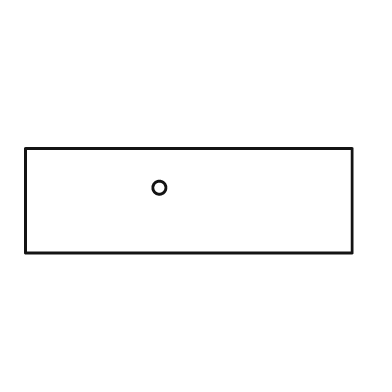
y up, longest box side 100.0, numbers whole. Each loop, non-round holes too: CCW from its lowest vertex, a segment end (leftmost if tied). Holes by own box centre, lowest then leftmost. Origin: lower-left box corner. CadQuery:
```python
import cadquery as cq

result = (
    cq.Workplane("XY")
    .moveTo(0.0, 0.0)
    .lineTo(100.0, 0.0)
    .lineTo(100.0, 32.0)
    .lineTo(0.0, 32.0)
    .close()
    .moveTo(41.0, 20.0)
    .circle(2.0)
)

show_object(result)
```